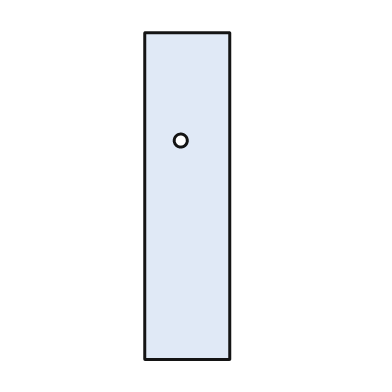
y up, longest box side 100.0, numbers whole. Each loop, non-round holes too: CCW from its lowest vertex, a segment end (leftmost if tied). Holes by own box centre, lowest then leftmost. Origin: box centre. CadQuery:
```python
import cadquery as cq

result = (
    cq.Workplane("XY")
    .moveTo(-13.0, -50.0)
    .lineTo(13.0, -50.0)
    .lineTo(13.0, 50.0)
    .lineTo(-13.0, 50.0)
    .close()
    .moveTo(-2.0, 17.0)
    .circle(2.0)
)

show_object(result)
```